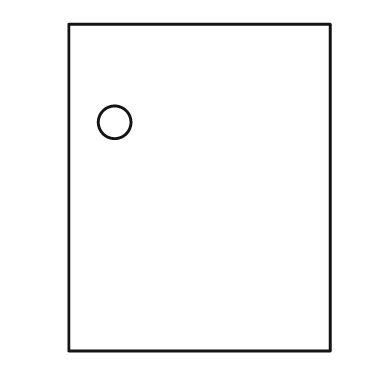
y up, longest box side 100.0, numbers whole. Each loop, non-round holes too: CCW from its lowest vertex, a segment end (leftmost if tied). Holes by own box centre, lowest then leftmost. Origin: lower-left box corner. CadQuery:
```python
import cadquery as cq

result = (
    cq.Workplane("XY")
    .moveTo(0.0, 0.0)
    .lineTo(80.0, 0.0)
    .lineTo(80.0, 100.0)
    .lineTo(0.0, 100.0)
    .close()
    .moveTo(14.0, 70.0)
    .circle(5.0)
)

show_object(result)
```